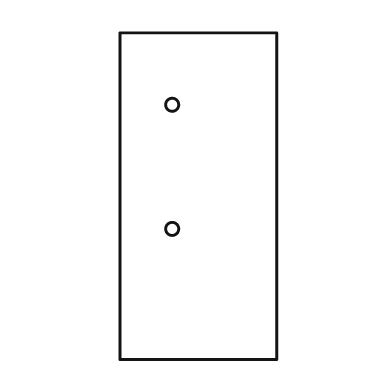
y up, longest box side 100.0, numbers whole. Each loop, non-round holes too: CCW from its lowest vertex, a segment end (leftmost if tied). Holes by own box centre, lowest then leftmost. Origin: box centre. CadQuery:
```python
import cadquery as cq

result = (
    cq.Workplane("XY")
    .moveTo(-24.0, -50.0)
    .lineTo(24.0, -50.0)
    .lineTo(24.0, 50.0)
    .lineTo(-24.0, 50.0)
    .close()
    .moveTo(-8.0, -10.0)
    .circle(2.0)
    .moveTo(-8.0, 28.0)
    .circle(2.0)
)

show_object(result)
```